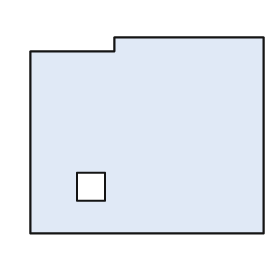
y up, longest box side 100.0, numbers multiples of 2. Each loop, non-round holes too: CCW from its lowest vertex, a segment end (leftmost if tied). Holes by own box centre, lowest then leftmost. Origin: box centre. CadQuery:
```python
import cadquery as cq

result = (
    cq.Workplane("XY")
    .moveTo(-50.0, -42.0)
    .lineTo(50.0, -42.0)
    .lineTo(50.0, 42.0)
    .lineTo(-14.0, 42.0)
    .lineTo(-14.0, 36.0)
    .lineTo(-50.0, 36.0)
    .close()
    .moveTo(-30.0, -28.0)
    .lineTo(-18.0, -28.0)
    .lineTo(-18.0, -16.0)
    .lineTo(-30.0, -16.0)
    .close()
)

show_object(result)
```